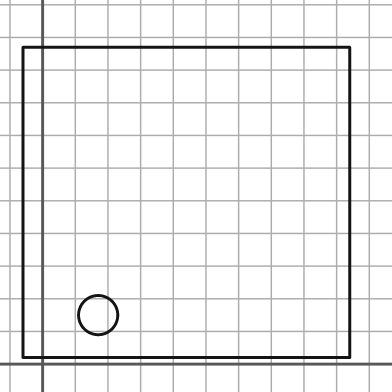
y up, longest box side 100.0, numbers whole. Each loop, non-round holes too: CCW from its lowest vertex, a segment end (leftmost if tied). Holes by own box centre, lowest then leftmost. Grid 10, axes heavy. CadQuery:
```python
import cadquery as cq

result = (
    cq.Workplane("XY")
    .moveTo(-6.0, 2.0)
    .lineTo(94.0, 2.0)
    .lineTo(94.0, 97.0)
    .lineTo(-6.0, 97.0)
    .close()
    .moveTo(17.0, 15.0)
    .circle(6.0)
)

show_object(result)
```